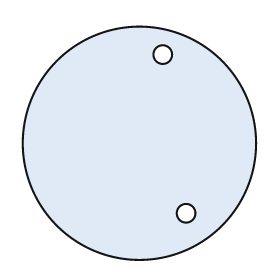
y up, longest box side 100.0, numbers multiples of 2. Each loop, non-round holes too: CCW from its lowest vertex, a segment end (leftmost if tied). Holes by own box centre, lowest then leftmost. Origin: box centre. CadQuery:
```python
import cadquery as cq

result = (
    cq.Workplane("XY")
    .moveTo(0.0, 0.0)
    .circle(50.0)
    .moveTo(20.0, -30.0)
    .circle(4.0)
    .moveTo(10.0, 38.0)
    .circle(4.0)
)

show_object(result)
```